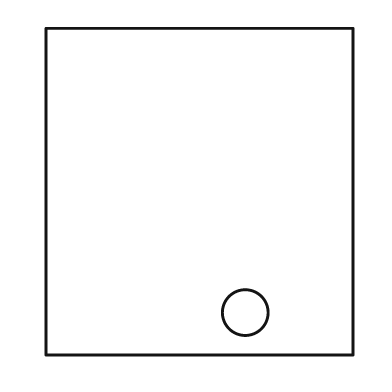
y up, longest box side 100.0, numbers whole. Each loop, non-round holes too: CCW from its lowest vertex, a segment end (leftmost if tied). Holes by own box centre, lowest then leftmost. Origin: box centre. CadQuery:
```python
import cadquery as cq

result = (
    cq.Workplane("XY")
    .moveTo(-47.0, -50.0)
    .lineTo(47.0, -50.0)
    .lineTo(47.0, 50.0)
    .lineTo(-47.0, 50.0)
    .close()
    .moveTo(14.0, -37.0)
    .circle(7.0)
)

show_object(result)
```